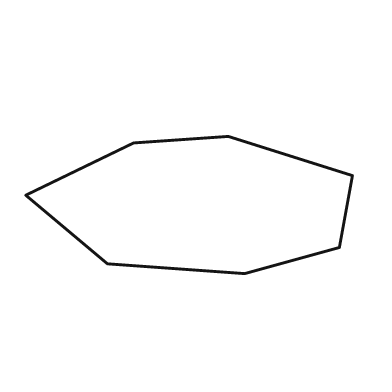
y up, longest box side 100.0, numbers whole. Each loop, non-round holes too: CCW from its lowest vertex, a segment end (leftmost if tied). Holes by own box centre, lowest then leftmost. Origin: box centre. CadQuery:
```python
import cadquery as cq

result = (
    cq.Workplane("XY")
    .moveTo(17.0, -21.0)
    .lineTo(46.0, -13.0)
    .lineTo(50.0, 9.0)
    .lineTo(12.0, 21.0)
    .lineTo(-17.0, 19.0)
    .lineTo(-50.0, 3.0)
    .lineTo(-25.0, -18.0)
    .close()
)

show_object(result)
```